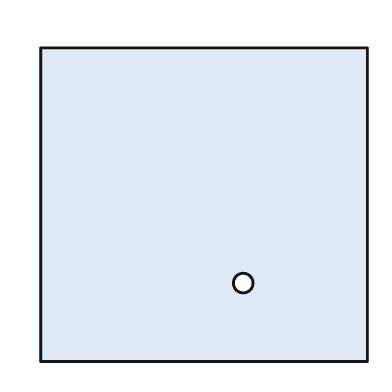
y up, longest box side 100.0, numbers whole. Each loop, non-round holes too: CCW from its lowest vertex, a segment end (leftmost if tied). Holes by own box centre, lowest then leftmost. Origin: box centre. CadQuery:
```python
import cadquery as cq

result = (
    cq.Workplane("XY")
    .moveTo(-50.0, -48.0)
    .lineTo(50.0, -48.0)
    .lineTo(50.0, 48.0)
    .lineTo(-50.0, 48.0)
    .close()
    .moveTo(12.0, -24.0)
    .circle(3.0)
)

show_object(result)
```